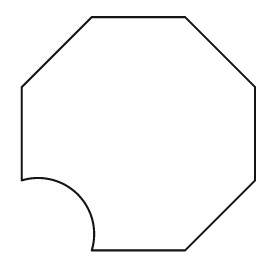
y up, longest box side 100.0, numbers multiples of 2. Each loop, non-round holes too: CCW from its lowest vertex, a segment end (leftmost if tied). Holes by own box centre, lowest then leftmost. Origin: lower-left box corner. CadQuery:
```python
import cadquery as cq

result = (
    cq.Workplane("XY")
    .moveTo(30.0, 0.0)
    .lineTo(70.0, 0.0)
    .lineTo(100.0, 30.0)
    .lineTo(100.0, 70.0)
    .lineTo(70.0, 100.0)
    .lineTo(30.0, 100.0)
    .lineTo(0.0, 70.0)
    .lineTo(0.0, 30.0)
    .threePointArc((24.0, 24.0), (30.0, 0.0))
    .close()
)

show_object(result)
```